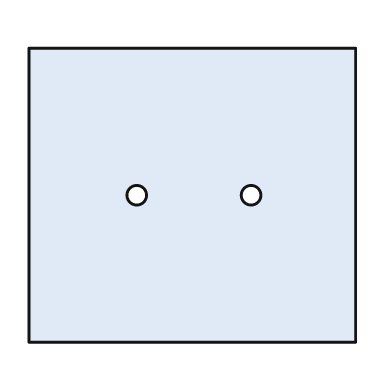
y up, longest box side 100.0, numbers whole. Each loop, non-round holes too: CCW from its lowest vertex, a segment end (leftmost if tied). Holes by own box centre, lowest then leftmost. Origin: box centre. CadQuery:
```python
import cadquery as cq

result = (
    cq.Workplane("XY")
    .moveTo(-50.0, -45.0)
    .lineTo(50.0, -45.0)
    .lineTo(50.0, 45.0)
    .lineTo(-50.0, 45.0)
    .close()
    .moveTo(-17.0, 0.0)
    .circle(3.0)
    .moveTo(18.0, 0.0)
    .circle(3.0)
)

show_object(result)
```